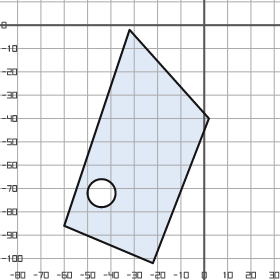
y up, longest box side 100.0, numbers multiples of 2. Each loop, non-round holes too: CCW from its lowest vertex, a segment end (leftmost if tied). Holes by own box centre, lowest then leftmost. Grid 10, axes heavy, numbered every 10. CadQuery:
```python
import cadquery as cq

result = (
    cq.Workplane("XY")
    .moveTo(-22.0, -102.0)
    .lineTo(2.0, -40.0)
    .lineTo(-32.0, -2.0)
    .lineTo(-60.0, -86.0)
    .close()
    .moveTo(-44.0, -72.0)
    .circle(6.0)
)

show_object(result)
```